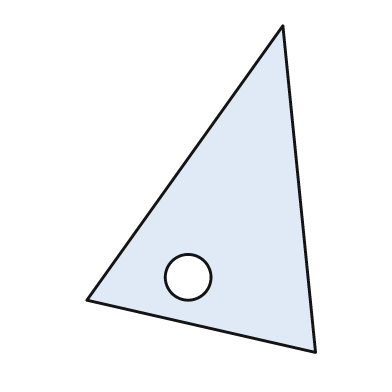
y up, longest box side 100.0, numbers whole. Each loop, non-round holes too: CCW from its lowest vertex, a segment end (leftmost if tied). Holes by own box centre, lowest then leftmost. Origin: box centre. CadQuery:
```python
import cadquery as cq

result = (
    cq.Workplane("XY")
    .moveTo(35.0, -50.0)
    .lineTo(25.0, 50.0)
    .lineTo(-35.0, -34.0)
    .close()
    .moveTo(-4.0, -27.0)
    .circle(7.0)
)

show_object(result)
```